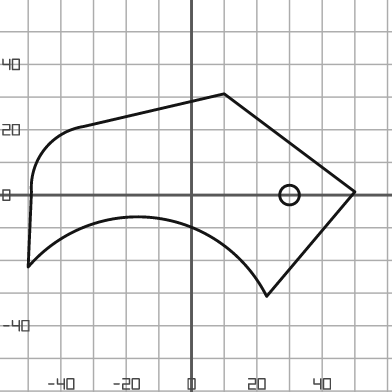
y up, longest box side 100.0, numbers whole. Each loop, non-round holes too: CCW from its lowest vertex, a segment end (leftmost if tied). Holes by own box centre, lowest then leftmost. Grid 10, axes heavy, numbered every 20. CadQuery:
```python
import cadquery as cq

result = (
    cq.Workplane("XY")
    .moveTo(23.0, -31.0)
    .lineTo(50.0, 1.0)
    .lineTo(10.0, 31.0)
    .lineTo(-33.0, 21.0)
    .threePointArc((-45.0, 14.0), (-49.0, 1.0))
    .lineTo(-50.0, -22.0)
    .threePointArc((-11.0, -7.0), (23.0, -31.0))
    .close()
    .moveTo(30.0, 0.0)
    .circle(3.0)
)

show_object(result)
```